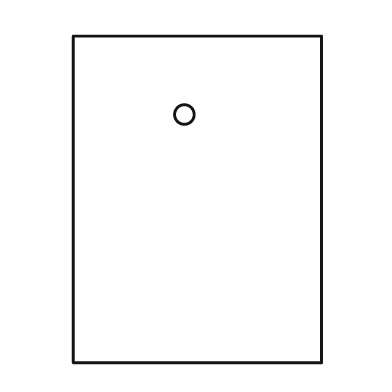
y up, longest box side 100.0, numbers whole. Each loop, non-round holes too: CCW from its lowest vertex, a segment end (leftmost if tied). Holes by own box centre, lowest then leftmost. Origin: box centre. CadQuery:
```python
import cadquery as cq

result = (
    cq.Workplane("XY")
    .moveTo(-38.0, -50.0)
    .lineTo(38.0, -50.0)
    .lineTo(38.0, 50.0)
    .lineTo(-38.0, 50.0)
    .close()
    .moveTo(-4.0, 26.0)
    .circle(3.0)
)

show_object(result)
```